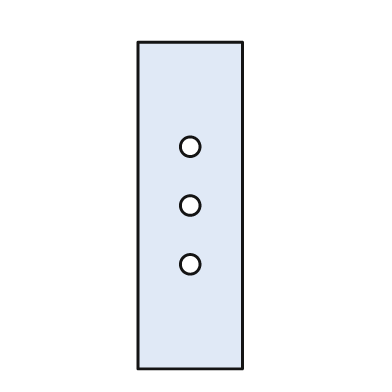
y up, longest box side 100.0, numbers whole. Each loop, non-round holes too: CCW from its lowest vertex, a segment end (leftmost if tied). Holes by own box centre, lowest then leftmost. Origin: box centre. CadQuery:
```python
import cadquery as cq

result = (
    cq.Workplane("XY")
    .moveTo(-16.0, -50.0)
    .lineTo(16.0, -50.0)
    .lineTo(16.0, 50.0)
    .lineTo(-16.0, 50.0)
    .close()
    .moveTo(0.0, -18.0)
    .circle(3.0)
    .moveTo(0.0, 0.0)
    .circle(3.0)
    .moveTo(0.0, 18.0)
    .circle(3.0)
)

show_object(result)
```